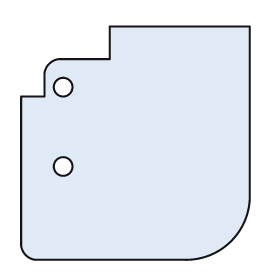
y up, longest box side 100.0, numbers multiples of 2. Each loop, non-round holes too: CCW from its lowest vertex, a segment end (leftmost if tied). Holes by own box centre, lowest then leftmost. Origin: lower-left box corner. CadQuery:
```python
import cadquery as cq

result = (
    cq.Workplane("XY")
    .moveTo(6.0, 0.0)
    .lineTo(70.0, 0.0)
    .threePointArc((90.0, 8.0), (98.0, 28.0))
    .lineTo(98.0, 100.0)
    .lineTo(38.0, 100.0)
    .lineTo(38.0, 86.0)
    .lineTo(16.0, 86.0)
    .threePointArc((12.0, 84.0), (10.0, 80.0))
    .lineTo(10.0, 70.0)
    .lineTo(0.0, 70.0)
    .lineTo(0.0, 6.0)
    .threePointArc((2.0, 2.0), (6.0, 0.0))
    .close()
    .moveTo(18.0, 40.0)
    .circle(4.0)
    .moveTo(18.0, 74.0)
    .circle(4.0)
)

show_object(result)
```